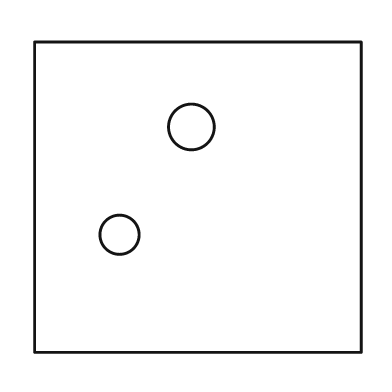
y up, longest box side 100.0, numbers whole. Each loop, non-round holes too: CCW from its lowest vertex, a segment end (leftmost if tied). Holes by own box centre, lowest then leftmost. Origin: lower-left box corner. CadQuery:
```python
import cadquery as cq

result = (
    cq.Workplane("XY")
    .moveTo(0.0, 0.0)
    .lineTo(100.0, 0.0)
    .lineTo(100.0, 95.0)
    .lineTo(0.0, 95.0)
    .close()
    .moveTo(26.0, 36.0)
    .circle(6.0)
    .moveTo(48.0, 69.0)
    .circle(7.0)
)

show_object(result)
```